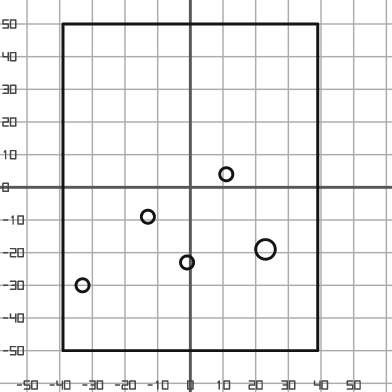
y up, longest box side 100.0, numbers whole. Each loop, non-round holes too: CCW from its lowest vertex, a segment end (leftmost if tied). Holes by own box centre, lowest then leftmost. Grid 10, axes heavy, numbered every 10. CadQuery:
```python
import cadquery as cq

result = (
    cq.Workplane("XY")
    .moveTo(-39.0, -50.0)
    .lineTo(39.0, -50.0)
    .lineTo(39.0, 50.0)
    .lineTo(-39.0, 50.0)
    .close()
    .moveTo(-33.0, -30.0)
    .circle(2.0)
    .moveTo(-1.0, -23.0)
    .circle(2.0)
    .moveTo(23.0, -19.0)
    .circle(3.0)
    .moveTo(-13.0, -9.0)
    .circle(2.0)
    .moveTo(11.0, 4.0)
    .circle(2.0)
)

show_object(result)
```